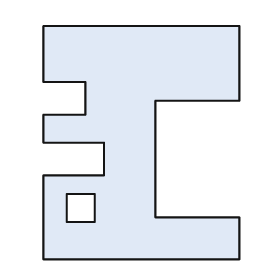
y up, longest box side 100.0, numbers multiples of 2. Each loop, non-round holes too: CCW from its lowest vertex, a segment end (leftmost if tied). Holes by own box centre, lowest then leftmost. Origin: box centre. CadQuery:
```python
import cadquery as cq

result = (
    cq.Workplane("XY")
    .moveTo(-42.0, -50.0)
    .lineTo(42.0, -50.0)
    .lineTo(42.0, -32.0)
    .lineTo(6.0, -32.0)
    .lineTo(6.0, 18.0)
    .lineTo(42.0, 18.0)
    .lineTo(42.0, 50.0)
    .lineTo(-42.0, 50.0)
    .lineTo(-42.0, 26.0)
    .lineTo(-24.0, 26.0)
    .lineTo(-24.0, 12.0)
    .lineTo(-42.0, 12.0)
    .lineTo(-42.0, 0.0)
    .lineTo(-16.0, 0.0)
    .lineTo(-16.0, -14.0)
    .lineTo(-42.0, -14.0)
    .close()
    .moveTo(-32.0, -34.0)
    .lineTo(-20.0, -34.0)
    .lineTo(-20.0, -22.0)
    .lineTo(-32.0, -22.0)
    .close()
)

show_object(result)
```